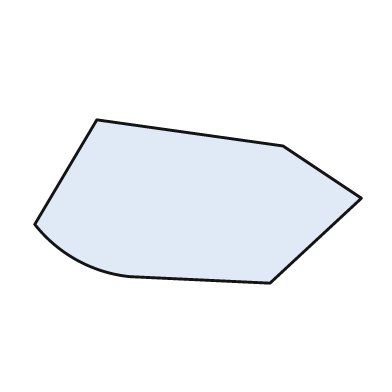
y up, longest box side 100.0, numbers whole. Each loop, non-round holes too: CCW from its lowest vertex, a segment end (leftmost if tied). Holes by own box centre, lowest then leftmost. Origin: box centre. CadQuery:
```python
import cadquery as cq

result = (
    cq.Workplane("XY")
    .moveTo(22.0, -25.0)
    .lineTo(50.0, 1.0)
    .lineTo(26.0, 17.0)
    .lineTo(-31.0, 25.0)
    .lineTo(-50.0, -7.0)
    .threePointArc((-37.0, -18.0), (-21.0, -23.0))
    .close()
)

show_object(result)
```